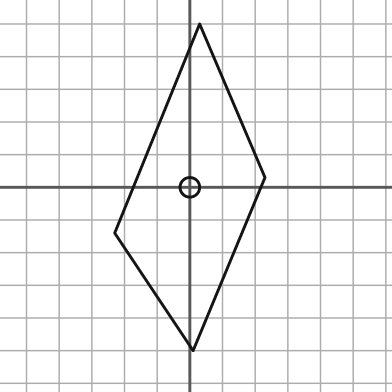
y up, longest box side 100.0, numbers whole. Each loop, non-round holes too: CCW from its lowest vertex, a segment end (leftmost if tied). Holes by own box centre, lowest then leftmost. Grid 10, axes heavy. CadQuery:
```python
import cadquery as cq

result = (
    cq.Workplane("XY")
    .moveTo(1.0, -50.0)
    .lineTo(23.0, 3.0)
    .lineTo(3.0, 50.0)
    .lineTo(-23.0, -14.0)
    .close()
    .moveTo(0.0, 0.0)
    .circle(3.0)
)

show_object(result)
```